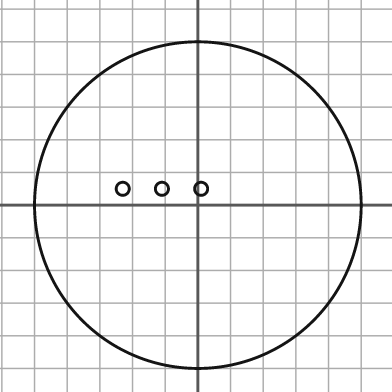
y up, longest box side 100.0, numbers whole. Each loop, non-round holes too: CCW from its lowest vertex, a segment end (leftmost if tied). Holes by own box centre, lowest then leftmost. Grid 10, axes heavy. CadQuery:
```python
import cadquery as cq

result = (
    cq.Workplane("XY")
    .moveTo(0.0, 0.0)
    .circle(50.0)
    .moveTo(-23.0, 5.0)
    .circle(2.0)
    .moveTo(-11.0, 5.0)
    .circle(2.0)
    .moveTo(1.0, 5.0)
    .circle(2.0)
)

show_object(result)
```